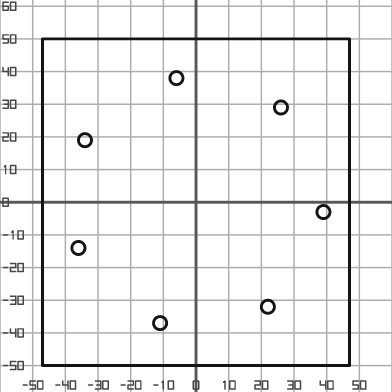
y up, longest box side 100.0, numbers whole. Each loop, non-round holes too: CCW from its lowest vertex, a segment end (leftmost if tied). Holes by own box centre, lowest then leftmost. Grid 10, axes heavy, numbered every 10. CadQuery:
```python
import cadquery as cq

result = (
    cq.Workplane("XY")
    .moveTo(-47.0, -50.0)
    .lineTo(47.0, -50.0)
    .lineTo(47.0, 50.0)
    .lineTo(-47.0, 50.0)
    .close()
    .moveTo(-11.0, -37.0)
    .circle(2.0)
    .moveTo(22.0, -32.0)
    .circle(2.0)
    .moveTo(-36.0, -14.0)
    .circle(2.0)
    .moveTo(39.0, -3.0)
    .circle(2.0)
    .moveTo(-34.0, 19.0)
    .circle(2.0)
    .moveTo(26.0, 29.0)
    .circle(2.0)
    .moveTo(-6.0, 38.0)
    .circle(2.0)
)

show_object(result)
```